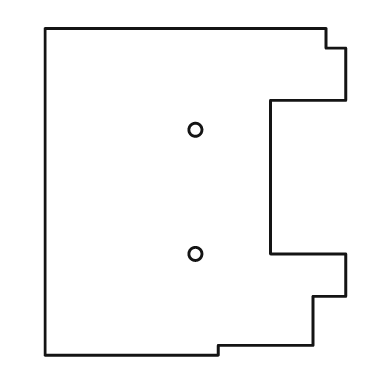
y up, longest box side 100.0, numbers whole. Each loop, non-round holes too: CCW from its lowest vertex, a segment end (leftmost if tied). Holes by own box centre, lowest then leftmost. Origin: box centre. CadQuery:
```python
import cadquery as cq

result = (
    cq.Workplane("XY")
    .moveTo(-46.0, -50.0)
    .lineTo(7.0, -50.0)
    .lineTo(7.0, -47.0)
    .lineTo(36.0, -47.0)
    .lineTo(36.0, -32.0)
    .lineTo(46.0, -32.0)
    .lineTo(46.0, -19.0)
    .lineTo(23.0, -19.0)
    .lineTo(23.0, 28.0)
    .lineTo(46.0, 28.0)
    .lineTo(46.0, 44.0)
    .lineTo(40.0, 44.0)
    .lineTo(40.0, 50.0)
    .lineTo(-46.0, 50.0)
    .close()
    .moveTo(0.0, -19.0)
    .circle(2.0)
    .moveTo(0.0, 19.0)
    .circle(2.0)
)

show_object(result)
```